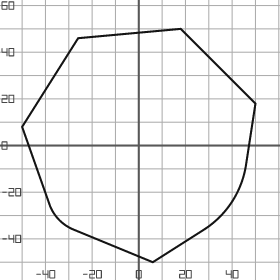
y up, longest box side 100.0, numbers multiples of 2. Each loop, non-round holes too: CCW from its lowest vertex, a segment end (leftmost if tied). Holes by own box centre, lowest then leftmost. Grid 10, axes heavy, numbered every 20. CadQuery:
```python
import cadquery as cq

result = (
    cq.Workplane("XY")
    .moveTo(6.0, -50.0)
    .lineTo(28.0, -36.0)
    .threePointArc((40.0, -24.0), (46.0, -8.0))
    .lineTo(50.0, 18.0)
    .lineTo(18.0, 50.0)
    .lineTo(-26.0, 46.0)
    .lineTo(-50.0, 8.0)
    .lineTo(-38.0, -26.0)
    .threePointArc((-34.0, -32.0), (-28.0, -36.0))
    .close()
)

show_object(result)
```